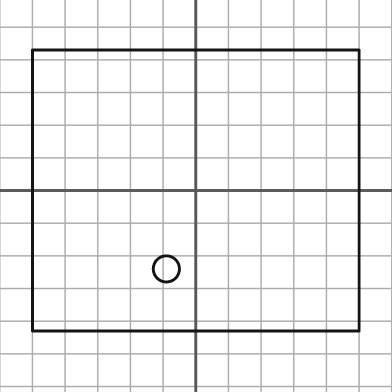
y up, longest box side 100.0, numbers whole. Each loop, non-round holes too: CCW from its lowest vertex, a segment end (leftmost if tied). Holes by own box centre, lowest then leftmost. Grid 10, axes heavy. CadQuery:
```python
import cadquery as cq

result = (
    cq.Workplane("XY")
    .moveTo(-50.0, -43.0)
    .lineTo(50.0, -43.0)
    .lineTo(50.0, 43.0)
    .lineTo(-50.0, 43.0)
    .close()
    .moveTo(-9.0, -24.0)
    .circle(4.0)
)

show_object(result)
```